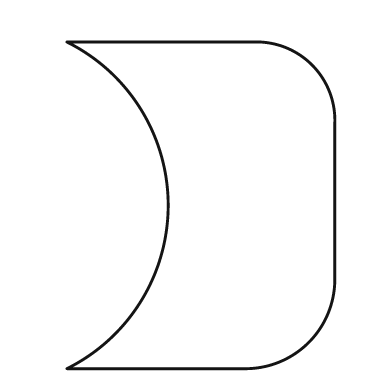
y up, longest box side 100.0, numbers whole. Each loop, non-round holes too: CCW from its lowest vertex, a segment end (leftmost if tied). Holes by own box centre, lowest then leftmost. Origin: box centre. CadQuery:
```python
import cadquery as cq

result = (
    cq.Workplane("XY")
    .moveTo(-41.0, -50.0)
    .lineTo(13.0, -50.0)
    .threePointArc((33.0, -42.0), (41.0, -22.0))
    .lineTo(41.0, 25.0)
    .threePointArc((34.0, 43.0), (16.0, 50.0))
    .lineTo(-41.0, 50.0)
    .threePointArc((-10.0, 0.0), (-41.0, -50.0))
    .close()
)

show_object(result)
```